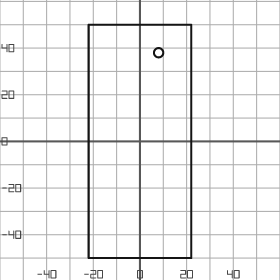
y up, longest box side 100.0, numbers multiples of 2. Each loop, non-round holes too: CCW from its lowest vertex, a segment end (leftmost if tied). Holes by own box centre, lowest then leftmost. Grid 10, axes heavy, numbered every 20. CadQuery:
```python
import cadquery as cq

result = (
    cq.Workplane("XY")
    .moveTo(-22.0, -50.0)
    .lineTo(22.0, -50.0)
    .lineTo(22.0, 50.0)
    .lineTo(-22.0, 50.0)
    .close()
    .moveTo(8.0, 38.0)
    .circle(2.0)
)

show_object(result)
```